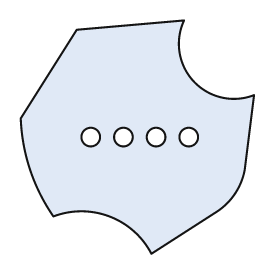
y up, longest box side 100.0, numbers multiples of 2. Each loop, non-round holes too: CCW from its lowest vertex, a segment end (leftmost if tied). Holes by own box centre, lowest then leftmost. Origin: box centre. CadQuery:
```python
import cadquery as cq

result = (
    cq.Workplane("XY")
    .moveTo(6.0, -50.0)
    .lineTo(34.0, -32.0)
    .threePointArc((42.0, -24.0), (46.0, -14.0))
    .lineTo(50.0, 18.0)
    .threePointArc((24.0, 24.0), (20.0, 50.0))
    .lineTo(-26.0, 46.0)
    .lineTo(-50.0, 8.0)
    .threePointArc((-46.0, -14.0), (-36.0, -34.0))
    .threePointArc((-12.0, -34.0), (6.0, -50.0))
    .close()
    .moveTo(-20.0, 0.0)
    .circle(4.0)
    .moveTo(-6.0, 0.0)
    .circle(4.0)
    .moveTo(8.0, 0.0)
    .circle(4.0)
    .moveTo(22.0, 0.0)
    .circle(4.0)
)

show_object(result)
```